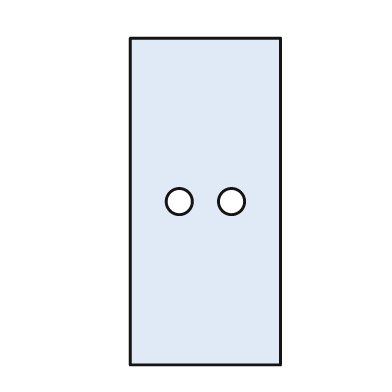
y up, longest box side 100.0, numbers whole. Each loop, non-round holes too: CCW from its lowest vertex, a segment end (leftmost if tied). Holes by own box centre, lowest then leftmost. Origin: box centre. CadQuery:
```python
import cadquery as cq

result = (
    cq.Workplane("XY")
    .moveTo(-23.0, -50.0)
    .lineTo(23.0, -50.0)
    .lineTo(23.0, 50.0)
    .lineTo(-23.0, 50.0)
    .close()
    .moveTo(-8.0, 0.0)
    .circle(4.0)
    .moveTo(8.0, 0.0)
    .circle(4.0)
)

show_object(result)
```